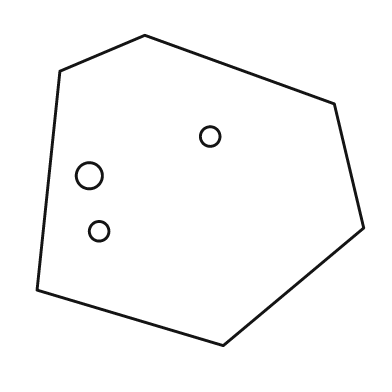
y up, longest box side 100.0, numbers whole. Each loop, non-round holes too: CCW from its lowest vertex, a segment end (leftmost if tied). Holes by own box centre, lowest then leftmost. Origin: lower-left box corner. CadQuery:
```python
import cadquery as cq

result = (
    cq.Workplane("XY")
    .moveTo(57.0, 0.0)
    .lineTo(100.0, 36.0)
    .lineTo(91.0, 74.0)
    .lineTo(33.0, 95.0)
    .lineTo(7.0, 84.0)
    .lineTo(0.0, 17.0)
    .close()
    .moveTo(19.0, 35.0)
    .circle(3.0)
    .moveTo(16.0, 52.0)
    .circle(4.0)
    .moveTo(53.0, 64.0)
    .circle(3.0)
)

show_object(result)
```